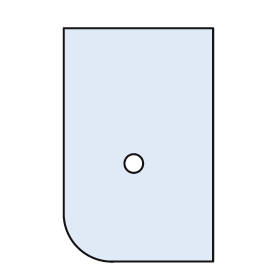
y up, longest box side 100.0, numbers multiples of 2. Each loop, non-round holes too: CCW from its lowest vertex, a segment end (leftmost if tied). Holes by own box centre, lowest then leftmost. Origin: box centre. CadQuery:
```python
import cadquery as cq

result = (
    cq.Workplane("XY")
    .moveTo(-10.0, -50.0)
    .lineTo(32.0, -50.0)
    .lineTo(32.0, 50.0)
    .lineTo(-32.0, 50.0)
    .lineTo(-32.0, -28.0)
    .threePointArc((-26.0, -44.0), (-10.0, -50.0))
    .close()
    .moveTo(-2.0, -8.0)
    .circle(4.0)
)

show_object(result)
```